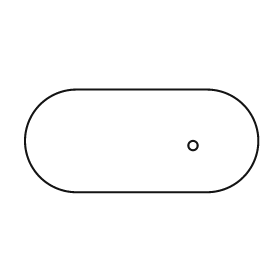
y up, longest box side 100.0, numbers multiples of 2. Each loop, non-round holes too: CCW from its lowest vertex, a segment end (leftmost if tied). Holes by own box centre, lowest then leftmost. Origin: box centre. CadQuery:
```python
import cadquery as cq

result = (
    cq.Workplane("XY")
    .moveTo(-28.0, -22.0)
    .lineTo(28.0, -22.0)
    .threePointArc((50.0, 0.0), (28.0, 22.0))
    .lineTo(-28.0, 22.0)
    .threePointArc((-50.0, 0.0), (-28.0, -22.0))
    .close()
    .moveTo(22.0, -2.0)
    .circle(2.0)
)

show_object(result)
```